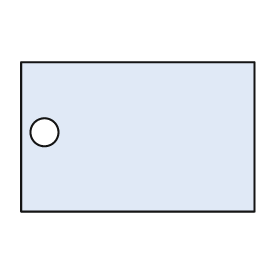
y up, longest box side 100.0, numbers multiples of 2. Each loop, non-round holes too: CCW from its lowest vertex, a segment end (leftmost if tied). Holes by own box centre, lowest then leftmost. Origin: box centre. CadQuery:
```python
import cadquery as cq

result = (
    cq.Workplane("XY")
    .moveTo(-50.0, -32.0)
    .lineTo(50.0, -32.0)
    .lineTo(50.0, 32.0)
    .lineTo(-50.0, 32.0)
    .close()
    .moveTo(-40.0, 2.0)
    .circle(6.0)
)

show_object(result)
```